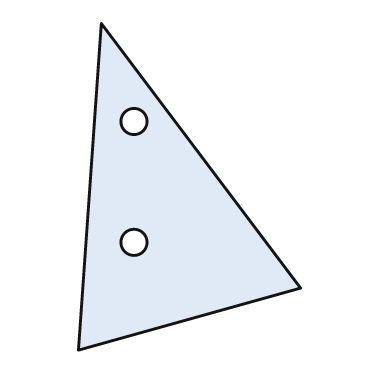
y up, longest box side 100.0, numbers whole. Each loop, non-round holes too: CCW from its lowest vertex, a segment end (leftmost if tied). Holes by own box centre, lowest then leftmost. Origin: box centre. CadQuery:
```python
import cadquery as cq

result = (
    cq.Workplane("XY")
    .moveTo(-34.0, -50.0)
    .lineTo(34.0, -31.0)
    .lineTo(-27.0, 50.0)
    .close()
    .moveTo(-17.0, -17.0)
    .circle(4.0)
    .moveTo(-17.0, 20.0)
    .circle(4.0)
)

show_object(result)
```